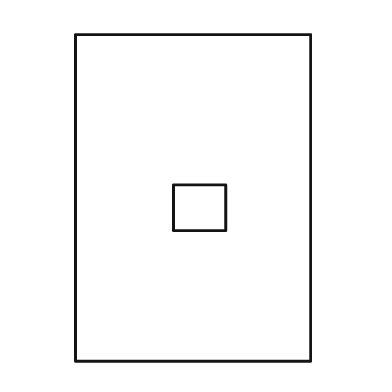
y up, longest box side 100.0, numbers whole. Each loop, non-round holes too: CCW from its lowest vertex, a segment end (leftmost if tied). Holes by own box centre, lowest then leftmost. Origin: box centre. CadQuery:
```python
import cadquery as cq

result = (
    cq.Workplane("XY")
    .moveTo(-36.0, -50.0)
    .lineTo(36.0, -50.0)
    .lineTo(36.0, 50.0)
    .lineTo(-36.0, 50.0)
    .close()
    .moveTo(-6.0, -10.0)
    .lineTo(10.0, -10.0)
    .lineTo(10.0, 4.0)
    .lineTo(-6.0, 4.0)
    .close()
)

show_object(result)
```